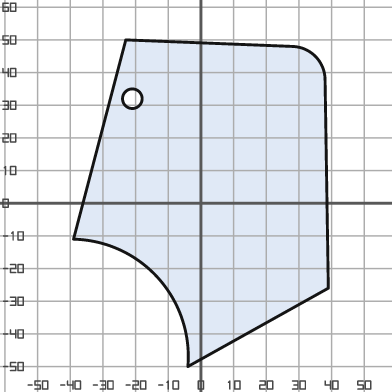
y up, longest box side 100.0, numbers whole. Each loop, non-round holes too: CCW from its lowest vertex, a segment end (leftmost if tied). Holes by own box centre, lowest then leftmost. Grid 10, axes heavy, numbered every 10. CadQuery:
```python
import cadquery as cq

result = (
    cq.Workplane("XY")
    .moveTo(-4.0, -50.0)
    .lineTo(39.0, -26.0)
    .lineTo(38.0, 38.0)
    .threePointArc((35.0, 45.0), (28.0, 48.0))
    .lineTo(-23.0, 50.0)
    .lineTo(-39.0, -11.0)
    .threePointArc((-13.0, -23.0), (-4.0, -50.0))
    .close()
    .moveTo(-21.0, 32.0)
    .circle(3.0)
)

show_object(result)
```